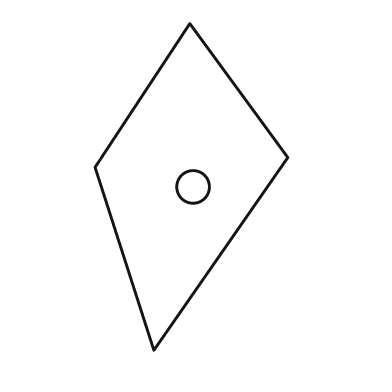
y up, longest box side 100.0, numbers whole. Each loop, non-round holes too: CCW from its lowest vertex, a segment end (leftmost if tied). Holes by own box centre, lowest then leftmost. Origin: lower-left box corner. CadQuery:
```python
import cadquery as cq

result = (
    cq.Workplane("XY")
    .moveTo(18.0, 0.0)
    .lineTo(59.0, 59.0)
    .lineTo(29.0, 100.0)
    .lineTo(0.0, 56.0)
    .close()
    .moveTo(30.0, 50.0)
    .circle(5.0)
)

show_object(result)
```